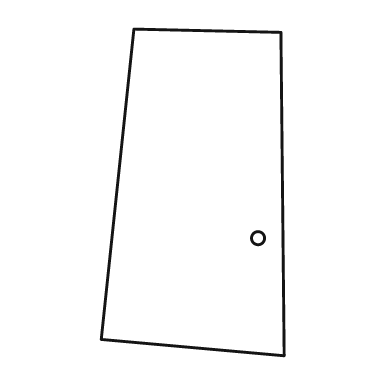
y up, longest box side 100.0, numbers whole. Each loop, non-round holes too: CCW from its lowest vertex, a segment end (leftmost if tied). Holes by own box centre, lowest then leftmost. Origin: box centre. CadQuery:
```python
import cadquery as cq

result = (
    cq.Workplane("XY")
    .moveTo(28.0, -50.0)
    .lineTo(27.0, 49.0)
    .lineTo(-18.0, 50.0)
    .lineTo(-28.0, -45.0)
    .close()
    .moveTo(20.0, -14.0)
    .circle(2.0)
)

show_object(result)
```